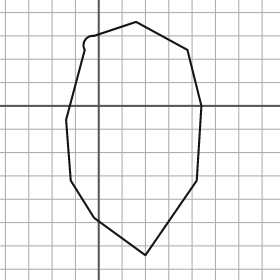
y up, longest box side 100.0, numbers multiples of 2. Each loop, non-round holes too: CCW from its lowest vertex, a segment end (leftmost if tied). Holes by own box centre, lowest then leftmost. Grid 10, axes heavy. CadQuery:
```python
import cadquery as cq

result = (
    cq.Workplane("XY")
    .moveTo(20.0, -64.0)
    .lineTo(42.0, -32.0)
    .lineTo(44.0, 0.0)
    .lineTo(38.0, 24.0)
    .lineTo(16.0, 36.0)
    .lineTo(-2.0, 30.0)
    .threePointArc((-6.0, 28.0), (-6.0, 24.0))
    .lineTo(-14.0, -6.0)
    .lineTo(-12.0, -32.0)
    .lineTo(-2.0, -48.0)
    .close()
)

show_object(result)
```